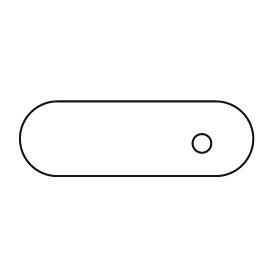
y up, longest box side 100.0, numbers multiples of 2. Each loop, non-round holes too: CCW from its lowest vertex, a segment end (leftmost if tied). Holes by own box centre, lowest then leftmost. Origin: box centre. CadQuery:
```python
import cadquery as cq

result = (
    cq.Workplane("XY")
    .moveTo(-34.0, -16.0)
    .lineTo(34.0, -16.0)
    .threePointArc((50.0, 0.0), (34.0, 16.0))
    .lineTo(-34.0, 16.0)
    .threePointArc((-50.0, 0.0), (-34.0, -16.0))
    .close()
    .moveTo(28.0, -2.0)
    .circle(4.0)
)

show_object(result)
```